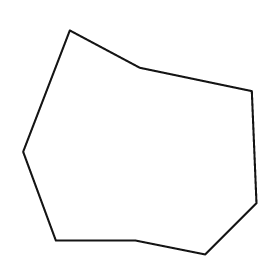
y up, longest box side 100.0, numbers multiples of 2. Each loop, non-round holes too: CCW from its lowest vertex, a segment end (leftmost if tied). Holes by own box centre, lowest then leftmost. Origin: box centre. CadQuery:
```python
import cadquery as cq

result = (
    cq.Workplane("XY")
    .moveTo(28.0, -48.0)
    .lineTo(50.0, -26.0)
    .lineTo(48.0, 22.0)
    .lineTo(0.0, 32.0)
    .lineTo(-30.0, 48.0)
    .lineTo(-50.0, -4.0)
    .lineTo(-36.0, -42.0)
    .lineTo(-2.0, -42.0)
    .close()
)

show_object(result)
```